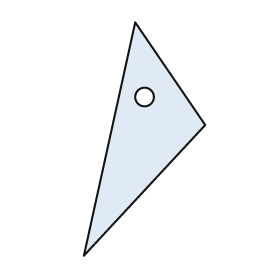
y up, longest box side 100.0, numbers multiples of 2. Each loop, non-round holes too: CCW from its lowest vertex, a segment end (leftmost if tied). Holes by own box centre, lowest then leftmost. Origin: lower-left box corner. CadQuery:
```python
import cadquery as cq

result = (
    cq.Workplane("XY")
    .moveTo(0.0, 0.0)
    .lineTo(52.0, 56.0)
    .lineTo(22.0, 100.0)
    .close()
    .moveTo(26.0, 68.0)
    .circle(4.0)
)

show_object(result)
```